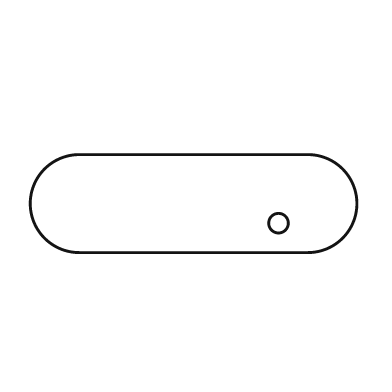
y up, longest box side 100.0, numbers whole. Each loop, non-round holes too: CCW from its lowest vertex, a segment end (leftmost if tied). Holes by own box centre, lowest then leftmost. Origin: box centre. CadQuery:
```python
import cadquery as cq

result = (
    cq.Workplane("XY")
    .moveTo(-35.0, -15.0)
    .lineTo(35.0, -15.0)
    .threePointArc((50.0, 0.0), (35.0, 15.0))
    .lineTo(-35.0, 15.0)
    .threePointArc((-50.0, 0.0), (-35.0, -15.0))
    .close()
    .moveTo(26.0, -6.0)
    .circle(3.0)
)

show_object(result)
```